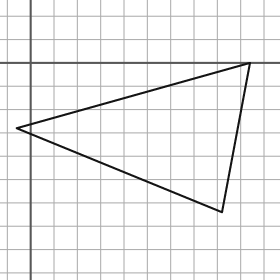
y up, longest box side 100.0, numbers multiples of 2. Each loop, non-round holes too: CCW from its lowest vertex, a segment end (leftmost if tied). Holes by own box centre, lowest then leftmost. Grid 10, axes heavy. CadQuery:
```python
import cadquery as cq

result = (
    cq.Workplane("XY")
    .moveTo(82.0, -64.0)
    .lineTo(94.0, 0.0)
    .lineTo(-6.0, -28.0)
    .close()
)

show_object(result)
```